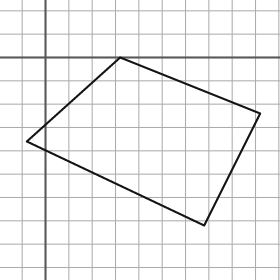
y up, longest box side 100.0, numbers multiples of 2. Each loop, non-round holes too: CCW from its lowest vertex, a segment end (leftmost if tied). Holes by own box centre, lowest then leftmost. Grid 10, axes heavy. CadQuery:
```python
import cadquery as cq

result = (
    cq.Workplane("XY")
    .moveTo(68.0, -72.0)
    .lineTo(92.0, -24.0)
    .lineTo(32.0, 0.0)
    .lineTo(-8.0, -36.0)
    .close()
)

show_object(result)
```